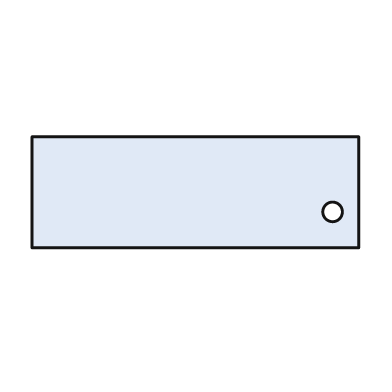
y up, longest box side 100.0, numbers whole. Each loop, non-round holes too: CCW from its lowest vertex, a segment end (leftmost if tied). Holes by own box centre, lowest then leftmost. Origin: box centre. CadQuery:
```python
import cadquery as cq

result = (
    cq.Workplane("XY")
    .moveTo(-50.0, -17.0)
    .lineTo(50.0, -17.0)
    .lineTo(50.0, 17.0)
    .lineTo(-50.0, 17.0)
    .close()
    .moveTo(42.0, -6.0)
    .circle(3.0)
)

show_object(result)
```